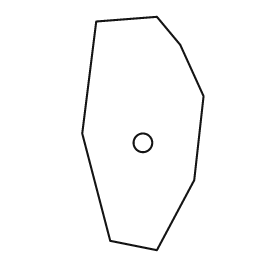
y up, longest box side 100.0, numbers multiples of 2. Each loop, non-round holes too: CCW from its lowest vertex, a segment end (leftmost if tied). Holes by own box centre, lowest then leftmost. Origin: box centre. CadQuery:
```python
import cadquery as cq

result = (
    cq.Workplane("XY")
    .moveTo(6.0, -50.0)
    .lineTo(22.0, -20.0)
    .lineTo(26.0, 16.0)
    .lineTo(16.0, 38.0)
    .lineTo(6.0, 50.0)
    .lineTo(-20.0, 48.0)
    .lineTo(-26.0, 0.0)
    .lineTo(-14.0, -46.0)
    .close()
    .moveTo(0.0, -4.0)
    .circle(4.0)
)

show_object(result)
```